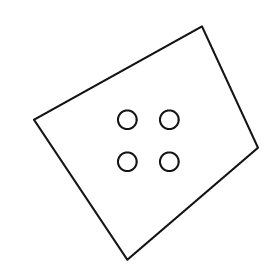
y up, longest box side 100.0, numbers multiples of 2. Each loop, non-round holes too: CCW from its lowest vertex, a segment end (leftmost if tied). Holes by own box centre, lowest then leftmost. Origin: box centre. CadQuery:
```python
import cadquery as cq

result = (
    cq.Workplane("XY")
    .moveTo(-8.0, -50.0)
    .lineTo(48.0, -2.0)
    .lineTo(24.0, 50.0)
    .lineTo(-48.0, 10.0)
    .close()
    .moveTo(-8.0, -8.0)
    .circle(4.0)
    .moveTo(10.0, -8.0)
    .circle(4.0)
    .moveTo(-8.0, 10.0)
    .circle(4.0)
    .moveTo(10.0, 10.0)
    .circle(4.0)
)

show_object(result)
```